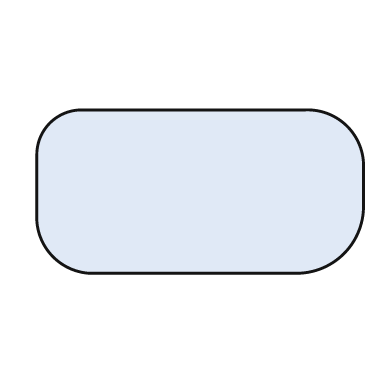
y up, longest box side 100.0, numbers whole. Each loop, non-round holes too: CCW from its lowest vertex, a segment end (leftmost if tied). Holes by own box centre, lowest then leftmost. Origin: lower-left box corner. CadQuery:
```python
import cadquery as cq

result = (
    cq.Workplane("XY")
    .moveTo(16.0, 0.0)
    .lineTo(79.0, 0.0)
    .threePointArc((94.0, 6.0), (100.0, 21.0))
    .lineTo(100.0, 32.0)
    .threePointArc((95.0, 45.0), (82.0, 50.0))
    .lineTo(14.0, 50.0)
    .threePointArc((4.0, 46.0), (0.0, 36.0))
    .lineTo(0.0, 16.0)
    .threePointArc((5.0, 5.0), (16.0, 0.0))
    .close()
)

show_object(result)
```